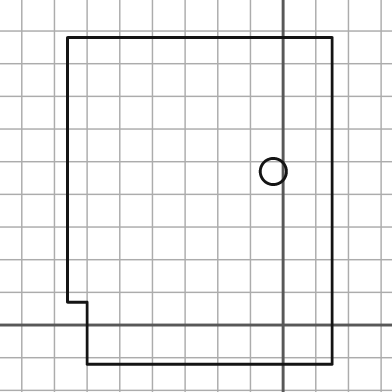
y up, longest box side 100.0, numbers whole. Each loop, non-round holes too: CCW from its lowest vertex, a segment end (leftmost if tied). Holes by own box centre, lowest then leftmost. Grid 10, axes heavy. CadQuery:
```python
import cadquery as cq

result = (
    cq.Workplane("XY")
    .moveTo(-60.0, -12.0)
    .lineTo(15.0, -12.0)
    .lineTo(15.0, 88.0)
    .lineTo(-66.0, 88.0)
    .lineTo(-66.0, 7.0)
    .lineTo(-60.0, 7.0)
    .close()
    .moveTo(-3.0, 47.0)
    .circle(4.0)
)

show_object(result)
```